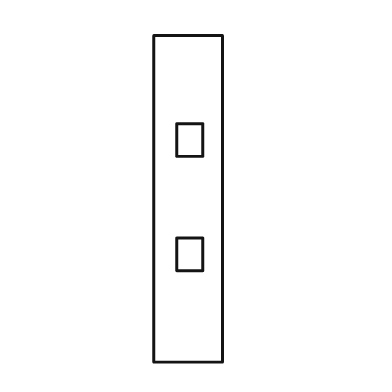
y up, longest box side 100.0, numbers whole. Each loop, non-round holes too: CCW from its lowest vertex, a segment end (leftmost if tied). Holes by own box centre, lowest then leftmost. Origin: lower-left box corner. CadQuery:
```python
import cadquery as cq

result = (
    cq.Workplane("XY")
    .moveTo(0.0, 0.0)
    .lineTo(21.0, 0.0)
    .lineTo(21.0, 100.0)
    .lineTo(0.0, 100.0)
    .close()
    .moveTo(7.0, 28.0)
    .lineTo(15.0, 28.0)
    .lineTo(15.0, 38.0)
    .lineTo(7.0, 38.0)
    .close()
    .moveTo(7.0, 63.0)
    .lineTo(15.0, 63.0)
    .lineTo(15.0, 73.0)
    .lineTo(7.0, 73.0)
    .close()
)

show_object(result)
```